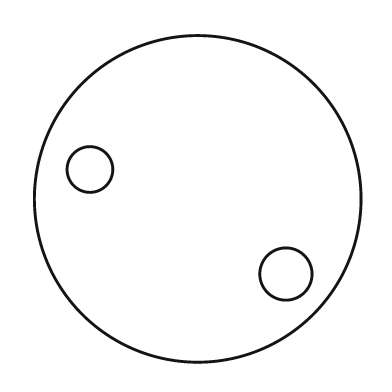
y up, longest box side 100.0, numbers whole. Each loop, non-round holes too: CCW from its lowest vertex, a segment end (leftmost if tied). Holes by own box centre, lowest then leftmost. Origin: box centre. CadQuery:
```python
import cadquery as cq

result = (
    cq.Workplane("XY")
    .moveTo(0.0, 0.0)
    .circle(50.0)
    .moveTo(27.0, -23.0)
    .circle(8.0)
    .moveTo(-33.0, 9.0)
    .circle(7.0)
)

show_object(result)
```